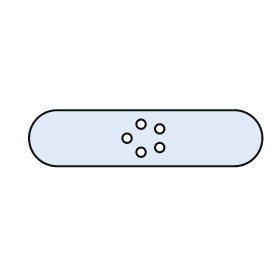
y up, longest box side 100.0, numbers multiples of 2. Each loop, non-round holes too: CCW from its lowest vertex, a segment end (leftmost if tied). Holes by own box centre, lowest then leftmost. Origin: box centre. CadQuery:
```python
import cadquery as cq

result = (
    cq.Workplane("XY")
    .moveTo(-38.0, -12.0)
    .lineTo(38.0, -12.0)
    .threePointArc((50.0, 0.0), (38.0, 12.0))
    .lineTo(-38.0, 12.0)
    .threePointArc((-50.0, 0.0), (-38.0, -12.0))
    .close()
    .moveTo(-2.0, -6.0)
    .circle(2.0)
    .moveTo(6.0, -4.0)
    .circle(2.0)
    .moveTo(-8.0, 0.0)
    .circle(2.0)
    .moveTo(6.0, 4.0)
    .circle(2.0)
    .moveTo(-2.0, 6.0)
    .circle(2.0)
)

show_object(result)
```